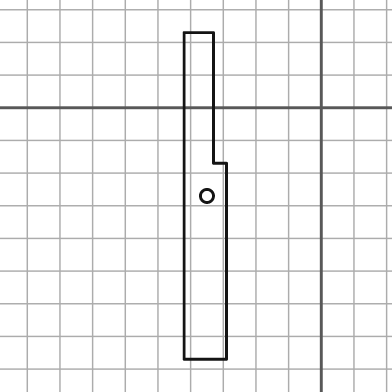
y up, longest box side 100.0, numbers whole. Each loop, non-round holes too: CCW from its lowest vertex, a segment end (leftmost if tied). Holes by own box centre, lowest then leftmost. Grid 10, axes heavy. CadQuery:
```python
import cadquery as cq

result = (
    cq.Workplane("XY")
    .moveTo(-42.0, -77.0)
    .lineTo(-29.0, -77.0)
    .lineTo(-29.0, -17.0)
    .lineTo(-33.0, -17.0)
    .lineTo(-33.0, 23.0)
    .lineTo(-42.0, 23.0)
    .close()
    .moveTo(-35.0, -27.0)
    .circle(2.0)
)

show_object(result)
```